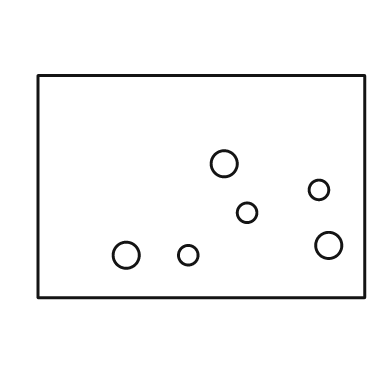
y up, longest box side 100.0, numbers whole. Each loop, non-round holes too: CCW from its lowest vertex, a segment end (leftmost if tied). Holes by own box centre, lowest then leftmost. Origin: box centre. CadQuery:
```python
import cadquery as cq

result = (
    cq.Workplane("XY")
    .moveTo(-50.0, -34.0)
    .lineTo(50.0, -34.0)
    .lineTo(50.0, 34.0)
    .lineTo(-50.0, 34.0)
    .close()
    .moveTo(-23.0, -21.0)
    .circle(4.0)
    .moveTo(-4.0, -21.0)
    .circle(3.0)
    .moveTo(39.0, -18.0)
    .circle(4.0)
    .moveTo(14.0, -8.0)
    .circle(3.0)
    .moveTo(36.0, -1.0)
    .circle(3.0)
    .moveTo(7.0, 7.0)
    .circle(4.0)
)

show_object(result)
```